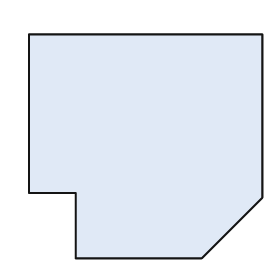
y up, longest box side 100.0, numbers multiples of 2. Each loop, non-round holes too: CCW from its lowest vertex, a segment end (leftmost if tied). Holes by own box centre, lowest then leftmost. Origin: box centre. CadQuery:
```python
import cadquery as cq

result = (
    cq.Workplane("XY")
    .moveTo(-30.0, -48.0)
    .lineTo(24.0, -48.0)
    .lineTo(50.0, -22.0)
    .lineTo(50.0, 48.0)
    .lineTo(-50.0, 48.0)
    .lineTo(-50.0, -20.0)
    .lineTo(-30.0, -20.0)
    .close()
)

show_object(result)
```